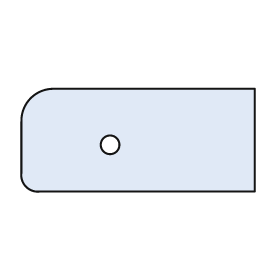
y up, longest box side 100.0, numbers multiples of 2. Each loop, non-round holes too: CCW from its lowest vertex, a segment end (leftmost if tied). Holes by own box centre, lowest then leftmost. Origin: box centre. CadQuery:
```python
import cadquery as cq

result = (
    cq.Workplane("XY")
    .moveTo(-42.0, -22.0)
    .lineTo(50.0, -22.0)
    .lineTo(50.0, 22.0)
    .lineTo(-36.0, 22.0)
    .threePointArc((-46.0, 18.0), (-50.0, 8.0))
    .lineTo(-50.0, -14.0)
    .threePointArc((-48.0, -20.0), (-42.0, -22.0))
    .close()
    .moveTo(-12.0, -2.0)
    .circle(4.0)
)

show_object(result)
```